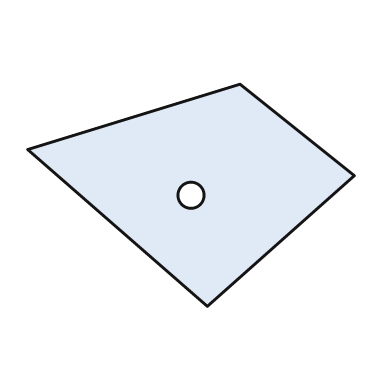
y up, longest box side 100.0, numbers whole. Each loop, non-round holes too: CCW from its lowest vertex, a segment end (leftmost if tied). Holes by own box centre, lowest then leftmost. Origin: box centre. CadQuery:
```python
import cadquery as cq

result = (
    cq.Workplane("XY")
    .moveTo(5.0, -34.0)
    .lineTo(50.0, 6.0)
    .lineTo(15.0, 34.0)
    .lineTo(-50.0, 14.0)
    .close()
    .moveTo(0.0, 0.0)
    .circle(4.0)
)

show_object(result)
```